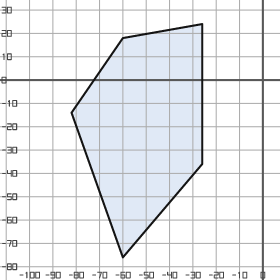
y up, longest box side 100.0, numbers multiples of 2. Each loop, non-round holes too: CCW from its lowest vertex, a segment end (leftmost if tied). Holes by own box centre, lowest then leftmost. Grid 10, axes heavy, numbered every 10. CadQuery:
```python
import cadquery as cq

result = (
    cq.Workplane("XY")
    .moveTo(-60.0, -76.0)
    .lineTo(-26.0, -36.0)
    .lineTo(-26.0, 24.0)
    .lineTo(-60.0, 18.0)
    .lineTo(-82.0, -14.0)
    .close()
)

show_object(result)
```